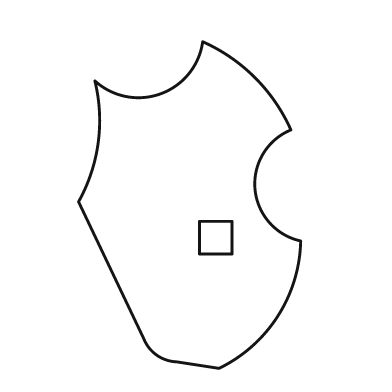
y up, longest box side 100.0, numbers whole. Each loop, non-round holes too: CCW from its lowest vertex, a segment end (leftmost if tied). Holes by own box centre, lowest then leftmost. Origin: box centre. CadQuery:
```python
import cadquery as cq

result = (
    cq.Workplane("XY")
    .moveTo(9.0, -50.0)
    .threePointArc((27.0, -34.0), (34.0, -11.0))
    .threePointArc((20.0, 5.0), (31.0, 23.0))
    .threePointArc((20.0, 39.0), (4.0, 50.0))
    .threePointArc((-9.0, 34.0), (-29.0, 38.0))
    .threePointArc((-28.0, 19.0), (-34.0, 1.0))
    .lineTo(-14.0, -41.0)
    .threePointArc((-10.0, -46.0), (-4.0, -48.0))
    .close()
    .moveTo(3.0, -15.0)
    .lineTo(13.0, -15.0)
    .lineTo(13.0, -5.0)
    .lineTo(3.0, -5.0)
    .close()
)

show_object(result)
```